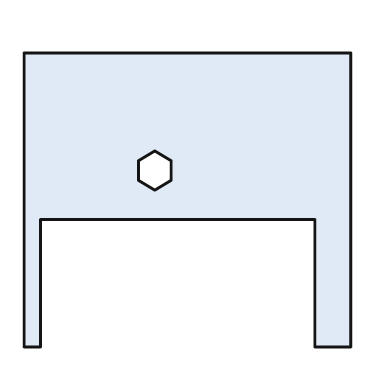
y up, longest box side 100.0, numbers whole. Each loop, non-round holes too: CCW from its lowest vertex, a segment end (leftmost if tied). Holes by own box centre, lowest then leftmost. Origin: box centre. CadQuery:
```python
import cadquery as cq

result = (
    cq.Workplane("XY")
    .moveTo(-50.0, -45.0)
    .lineTo(-45.0, -45.0)
    .lineTo(-45.0, -6.0)
    .lineTo(39.0, -6.0)
    .lineTo(39.0, -45.0)
    .lineTo(50.0, -45.0)
    .lineTo(50.0, 45.0)
    .lineTo(-50.0, 45.0)
    .close()
    .moveTo(-10.0, 3.0)
    .lineTo(-5.0, 6.0)
    .lineTo(-5.0, 12.0)
    .lineTo(-10.0, 15.0)
    .lineTo(-15.0, 12.0)
    .lineTo(-15.0, 6.0)
    .close()
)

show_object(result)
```